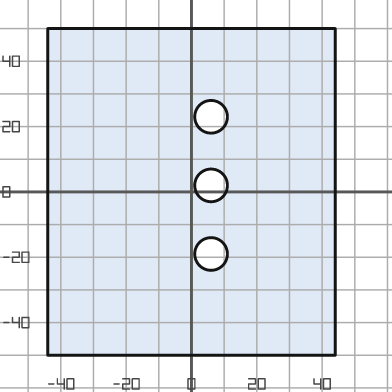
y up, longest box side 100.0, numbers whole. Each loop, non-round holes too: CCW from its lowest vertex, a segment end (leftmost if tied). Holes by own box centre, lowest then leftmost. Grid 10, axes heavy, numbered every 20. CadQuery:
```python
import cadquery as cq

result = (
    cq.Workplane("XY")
    .moveTo(-44.0, -50.0)
    .lineTo(44.0, -50.0)
    .lineTo(44.0, 50.0)
    .lineTo(-44.0, 50.0)
    .close()
    .moveTo(6.0, -19.0)
    .circle(5.0)
    .moveTo(6.0, 2.0)
    .circle(5.0)
    .moveTo(6.0, 23.0)
    .circle(5.0)
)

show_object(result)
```